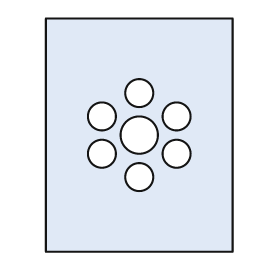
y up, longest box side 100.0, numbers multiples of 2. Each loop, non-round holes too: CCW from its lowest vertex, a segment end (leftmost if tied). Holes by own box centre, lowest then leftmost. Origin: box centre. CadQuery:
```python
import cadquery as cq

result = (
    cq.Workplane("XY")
    .moveTo(-40.0, -50.0)
    .lineTo(40.0, -50.0)
    .lineTo(40.0, 50.0)
    .lineTo(-40.0, 50.0)
    .close()
    .moveTo(0.0, -18.0)
    .circle(6.0)
    .moveTo(-16.0, -8.0)
    .circle(6.0)
    .moveTo(16.0, -8.0)
    .circle(6.0)
    .moveTo(0.0, 0.0)
    .circle(8.0)
    .moveTo(-16.0, 8.0)
    .circle(6.0)
    .moveTo(16.0, 8.0)
    .circle(6.0)
    .moveTo(0.0, 18.0)
    .circle(6.0)
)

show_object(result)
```